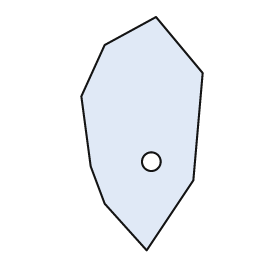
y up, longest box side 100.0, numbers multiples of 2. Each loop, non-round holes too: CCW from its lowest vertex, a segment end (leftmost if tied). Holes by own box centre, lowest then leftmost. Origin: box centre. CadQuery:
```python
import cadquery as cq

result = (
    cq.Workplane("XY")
    .moveTo(2.0, -50.0)
    .lineTo(22.0, -20.0)
    .lineTo(26.0, 26.0)
    .lineTo(6.0, 50.0)
    .lineTo(-16.0, 38.0)
    .lineTo(-26.0, 16.0)
    .lineTo(-22.0, -14.0)
    .lineTo(-16.0, -30.0)
    .close()
    .moveTo(4.0, -12.0)
    .circle(4.0)
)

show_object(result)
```